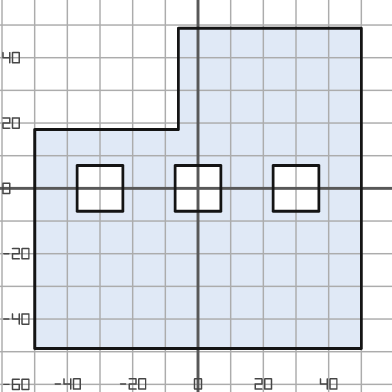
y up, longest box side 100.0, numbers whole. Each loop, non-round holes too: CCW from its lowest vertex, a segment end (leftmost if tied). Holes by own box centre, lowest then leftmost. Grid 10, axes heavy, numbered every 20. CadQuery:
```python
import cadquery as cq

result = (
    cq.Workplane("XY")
    .moveTo(-50.0, -49.0)
    .lineTo(50.0, -49.0)
    .lineTo(50.0, 49.0)
    .lineTo(-6.0, 49.0)
    .lineTo(-6.0, 18.0)
    .lineTo(-50.0, 18.0)
    .close()
    .moveTo(-37.0, -7.0)
    .lineTo(-23.0, -7.0)
    .lineTo(-23.0, 7.0)
    .lineTo(-37.0, 7.0)
    .close()
    .moveTo(-7.0, -7.0)
    .lineTo(7.0, -7.0)
    .lineTo(7.0, 7.0)
    .lineTo(-7.0, 7.0)
    .close()
    .moveTo(23.0, -7.0)
    .lineTo(37.0, -7.0)
    .lineTo(37.0, 7.0)
    .lineTo(23.0, 7.0)
    .close()
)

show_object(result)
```